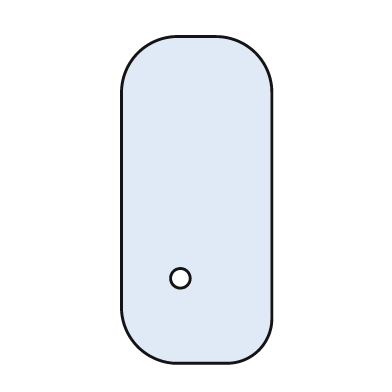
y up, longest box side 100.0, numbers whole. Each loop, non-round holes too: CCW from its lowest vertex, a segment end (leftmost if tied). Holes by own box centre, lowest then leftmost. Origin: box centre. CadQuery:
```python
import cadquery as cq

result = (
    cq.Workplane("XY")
    .moveTo(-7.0, -50.0)
    .lineTo(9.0, -50.0)
    .threePointArc((19.0, -46.0), (23.0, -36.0))
    .lineTo(23.0, 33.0)
    .threePointArc((18.0, 45.0), (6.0, 50.0))
    .lineTo(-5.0, 50.0)
    .threePointArc((-18.0, 45.0), (-23.0, 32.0))
    .lineTo(-23.0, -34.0)
    .threePointArc((-18.0, -45.0), (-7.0, -50.0))
    .close()
    .moveTo(-5.0, -24.0)
    .circle(3.0)
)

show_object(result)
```